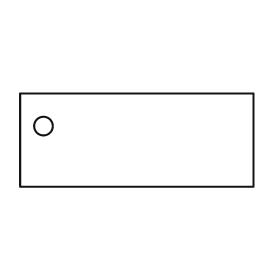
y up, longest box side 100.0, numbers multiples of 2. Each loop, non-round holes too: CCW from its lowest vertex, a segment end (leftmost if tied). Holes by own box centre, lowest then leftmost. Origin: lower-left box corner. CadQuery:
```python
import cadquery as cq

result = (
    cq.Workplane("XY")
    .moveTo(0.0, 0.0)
    .lineTo(100.0, 0.0)
    .lineTo(100.0, 40.0)
    .lineTo(0.0, 40.0)
    .close()
    .moveTo(10.0, 26.0)
    .circle(4.0)
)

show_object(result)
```